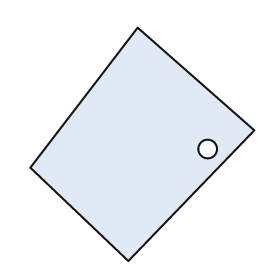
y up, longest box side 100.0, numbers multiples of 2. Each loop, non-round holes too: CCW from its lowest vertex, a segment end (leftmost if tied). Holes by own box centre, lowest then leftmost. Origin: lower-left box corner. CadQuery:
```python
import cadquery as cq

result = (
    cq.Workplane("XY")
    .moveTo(42.0, 0.0)
    .lineTo(96.0, 56.0)
    .lineTo(46.0, 100.0)
    .lineTo(0.0, 40.0)
    .close()
    .moveTo(76.0, 48.0)
    .circle(4.0)
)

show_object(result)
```